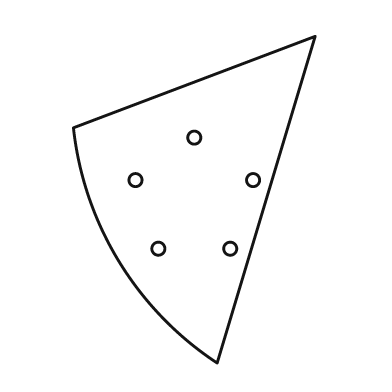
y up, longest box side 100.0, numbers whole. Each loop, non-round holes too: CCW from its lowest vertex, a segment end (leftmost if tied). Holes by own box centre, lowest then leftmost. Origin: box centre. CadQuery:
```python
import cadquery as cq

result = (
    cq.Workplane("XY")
    .moveTo(7.0, -50.0)
    .lineTo(37.0, 50.0)
    .lineTo(-37.0, 22.0)
    .threePointArc((-23.0, -19.0), (7.0, -50.0))
    .close()
    .moveTo(-11.0, -15.0)
    .circle(2.0)
    .moveTo(11.0, -15.0)
    .circle(2.0)
    .moveTo(-18.0, 6.0)
    .circle(2.0)
    .moveTo(18.0, 6.0)
    .circle(2.0)
    .moveTo(0.0, 19.0)
    .circle(2.0)
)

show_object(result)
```